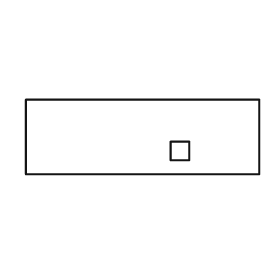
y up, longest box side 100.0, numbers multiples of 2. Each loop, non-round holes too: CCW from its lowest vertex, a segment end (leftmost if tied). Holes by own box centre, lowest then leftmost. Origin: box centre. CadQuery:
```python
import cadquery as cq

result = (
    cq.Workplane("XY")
    .moveTo(-50.0, -16.0)
    .lineTo(50.0, -16.0)
    .lineTo(50.0, 16.0)
    .lineTo(-50.0, 16.0)
    .close()
    .moveTo(12.0, -10.0)
    .lineTo(20.0, -10.0)
    .lineTo(20.0, -2.0)
    .lineTo(12.0, -2.0)
    .close()
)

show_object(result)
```